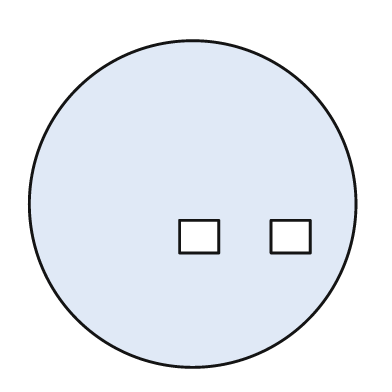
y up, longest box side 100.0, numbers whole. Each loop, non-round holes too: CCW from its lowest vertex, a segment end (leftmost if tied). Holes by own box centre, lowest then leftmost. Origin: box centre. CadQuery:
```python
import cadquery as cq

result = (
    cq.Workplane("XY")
    .moveTo(0.0, 0.0)
    .circle(50.0)
    .moveTo(-4.0, -15.0)
    .lineTo(8.0, -15.0)
    .lineTo(8.0, -5.0)
    .lineTo(-4.0, -5.0)
    .close()
    .moveTo(24.0, -15.0)
    .lineTo(36.0, -15.0)
    .lineTo(36.0, -5.0)
    .lineTo(24.0, -5.0)
    .close()
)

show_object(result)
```